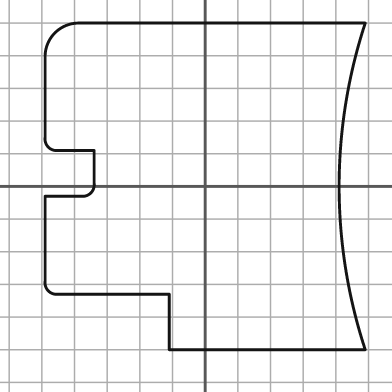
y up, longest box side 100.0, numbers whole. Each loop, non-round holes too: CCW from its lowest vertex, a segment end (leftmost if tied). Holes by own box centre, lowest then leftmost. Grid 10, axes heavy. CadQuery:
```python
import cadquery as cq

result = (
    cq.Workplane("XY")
    .moveTo(-11.0, -50.0)
    .lineTo(49.0, -50.0)
    .threePointArc((41.0, 0.0), (49.0, 50.0))
    .lineTo(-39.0, 50.0)
    .threePointArc((-46.0, 47.0), (-49.0, 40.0))
    .lineTo(-49.0, 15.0)
    .threePointArc((-48.0, 12.0), (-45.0, 11.0))
    .lineTo(-34.0, 11.0)
    .lineTo(-34.0, 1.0)
    .threePointArc((-35.0, -2.0), (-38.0, -3.0))
    .lineTo(-49.0, -3.0)
    .lineTo(-49.0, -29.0)
    .threePointArc((-48.0, -32.0), (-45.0, -33.0))
    .lineTo(-11.0, -33.0)
    .close()
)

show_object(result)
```